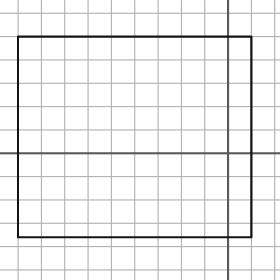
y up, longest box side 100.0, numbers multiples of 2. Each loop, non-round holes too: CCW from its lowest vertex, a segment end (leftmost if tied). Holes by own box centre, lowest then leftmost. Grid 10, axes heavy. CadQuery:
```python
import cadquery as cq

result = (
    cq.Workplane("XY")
    .moveTo(-90.0, -36.0)
    .lineTo(10.0, -36.0)
    .lineTo(10.0, 50.0)
    .lineTo(-90.0, 50.0)
    .close()
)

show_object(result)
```